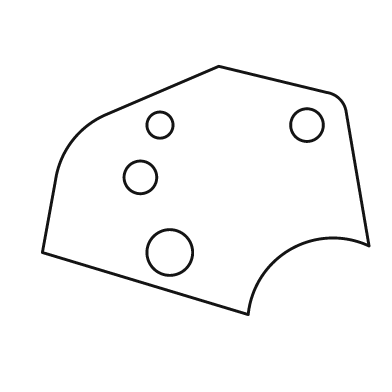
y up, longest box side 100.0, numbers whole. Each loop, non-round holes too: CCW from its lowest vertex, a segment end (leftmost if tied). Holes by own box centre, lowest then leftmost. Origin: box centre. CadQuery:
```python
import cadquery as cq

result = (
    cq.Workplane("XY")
    .moveTo(13.0, -38.0)
    .threePointArc((26.0, -18.0), (50.0, -17.0))
    .lineTo(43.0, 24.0)
    .threePointArc((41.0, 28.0), (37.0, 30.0))
    .lineTo(4.0, 38.0)
    .lineTo(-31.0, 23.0)
    .threePointArc((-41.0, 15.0), (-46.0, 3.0))
    .lineTo(-50.0, -19.0)
    .close()
    .moveTo(-11.0, -19.0)
    .circle(7.0)
    .moveTo(-20.0, 4.0)
    .circle(5.0)
    .moveTo(-14.0, 20.0)
    .circle(4.0)
    .moveTo(31.0, 20.0)
    .circle(5.0)
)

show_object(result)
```